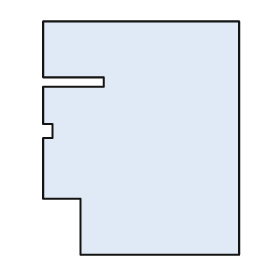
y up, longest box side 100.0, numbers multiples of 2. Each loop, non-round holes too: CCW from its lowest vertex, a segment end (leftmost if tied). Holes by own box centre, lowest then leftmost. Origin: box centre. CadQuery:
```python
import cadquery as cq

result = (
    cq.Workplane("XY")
    .moveTo(-26.0, -50.0)
    .lineTo(42.0, -50.0)
    .lineTo(42.0, 50.0)
    .lineTo(-42.0, 50.0)
    .lineTo(-42.0, 26.0)
    .lineTo(-16.0, 26.0)
    .lineTo(-16.0, 22.0)
    .lineTo(-42.0, 22.0)
    .lineTo(-42.0, 6.0)
    .lineTo(-38.0, 6.0)
    .lineTo(-38.0, 0.0)
    .lineTo(-42.0, 0.0)
    .lineTo(-42.0, -26.0)
    .lineTo(-26.0, -26.0)
    .close()
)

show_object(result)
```